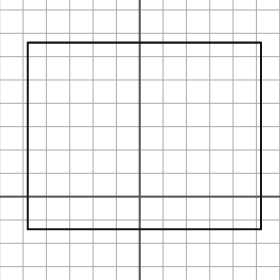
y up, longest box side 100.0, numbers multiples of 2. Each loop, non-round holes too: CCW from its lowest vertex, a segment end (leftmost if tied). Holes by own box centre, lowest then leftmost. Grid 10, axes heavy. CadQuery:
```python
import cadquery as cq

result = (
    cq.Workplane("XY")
    .moveTo(-48.0, -14.0)
    .lineTo(52.0, -14.0)
    .lineTo(52.0, 66.0)
    .lineTo(-48.0, 66.0)
    .close()
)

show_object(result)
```